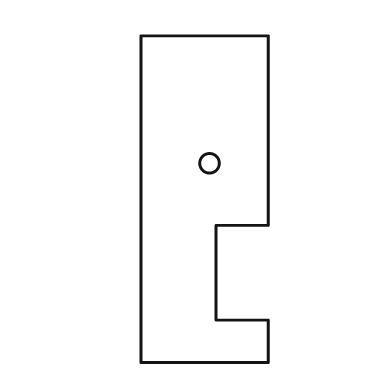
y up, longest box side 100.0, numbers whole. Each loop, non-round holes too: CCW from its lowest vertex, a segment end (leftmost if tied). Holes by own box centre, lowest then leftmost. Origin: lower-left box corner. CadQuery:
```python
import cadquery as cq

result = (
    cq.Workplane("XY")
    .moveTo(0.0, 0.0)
    .lineTo(39.0, 0.0)
    .lineTo(39.0, 13.0)
    .lineTo(23.0, 13.0)
    .lineTo(23.0, 42.0)
    .lineTo(39.0, 42.0)
    .lineTo(39.0, 100.0)
    .lineTo(0.0, 100.0)
    .close()
    .moveTo(21.0, 61.0)
    .circle(3.0)
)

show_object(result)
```